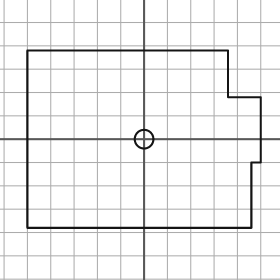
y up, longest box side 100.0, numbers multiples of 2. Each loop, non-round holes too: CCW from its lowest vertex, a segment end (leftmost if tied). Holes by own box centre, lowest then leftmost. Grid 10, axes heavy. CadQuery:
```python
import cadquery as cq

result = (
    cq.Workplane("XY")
    .moveTo(-50.0, -38.0)
    .lineTo(46.0, -38.0)
    .lineTo(46.0, -10.0)
    .lineTo(50.0, -10.0)
    .lineTo(50.0, 18.0)
    .lineTo(36.0, 18.0)
    .lineTo(36.0, 38.0)
    .lineTo(-50.0, 38.0)
    .close()
    .moveTo(0.0, 0.0)
    .circle(4.0)
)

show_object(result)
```